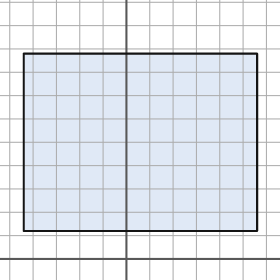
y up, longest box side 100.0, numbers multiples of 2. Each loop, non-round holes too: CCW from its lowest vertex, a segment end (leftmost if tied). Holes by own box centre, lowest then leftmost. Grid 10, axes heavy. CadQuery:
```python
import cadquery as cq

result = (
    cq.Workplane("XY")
    .moveTo(-44.0, 12.0)
    .lineTo(56.0, 12.0)
    .lineTo(56.0, 88.0)
    .lineTo(-44.0, 88.0)
    .close()
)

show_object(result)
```